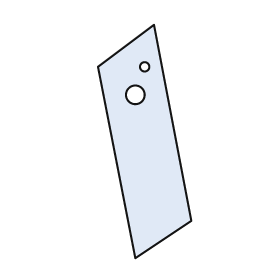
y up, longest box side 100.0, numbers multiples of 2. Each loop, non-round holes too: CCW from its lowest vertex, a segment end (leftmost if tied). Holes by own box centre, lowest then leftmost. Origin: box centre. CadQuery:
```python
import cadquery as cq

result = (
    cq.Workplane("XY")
    .moveTo(-4.0, -50.0)
    .lineTo(20.0, -34.0)
    .lineTo(4.0, 50.0)
    .lineTo(-20.0, 32.0)
    .close()
    .moveTo(-4.0, 20.0)
    .circle(4.0)
    .moveTo(0.0, 32.0)
    .circle(2.0)
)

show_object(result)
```